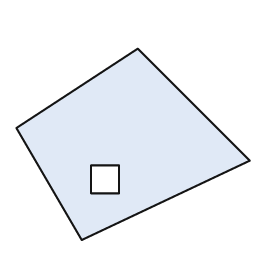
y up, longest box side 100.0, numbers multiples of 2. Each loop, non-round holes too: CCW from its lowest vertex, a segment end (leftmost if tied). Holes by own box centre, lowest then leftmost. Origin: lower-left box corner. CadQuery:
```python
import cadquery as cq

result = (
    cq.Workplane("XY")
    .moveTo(28.0, 0.0)
    .lineTo(100.0, 34.0)
    .lineTo(52.0, 82.0)
    .lineTo(0.0, 48.0)
    .close()
    .moveTo(32.0, 20.0)
    .lineTo(44.0, 20.0)
    .lineTo(44.0, 32.0)
    .lineTo(32.0, 32.0)
    .close()
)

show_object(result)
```